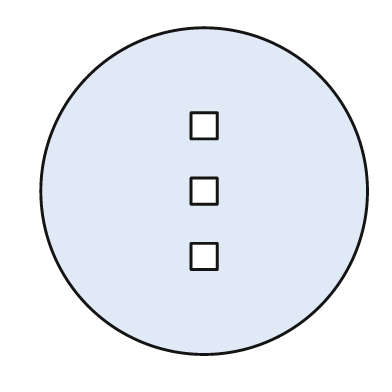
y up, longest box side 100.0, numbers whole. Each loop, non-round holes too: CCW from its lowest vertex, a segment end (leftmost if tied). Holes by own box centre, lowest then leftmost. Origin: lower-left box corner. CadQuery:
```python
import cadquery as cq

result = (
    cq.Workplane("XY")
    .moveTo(50.0, 50.0)
    .circle(50.0)
    .moveTo(46.0, 26.0)
    .lineTo(54.0, 26.0)
    .lineTo(54.0, 34.0)
    .lineTo(46.0, 34.0)
    .close()
    .moveTo(46.0, 46.0)
    .lineTo(54.0, 46.0)
    .lineTo(54.0, 54.0)
    .lineTo(46.0, 54.0)
    .close()
    .moveTo(46.0, 66.0)
    .lineTo(54.0, 66.0)
    .lineTo(54.0, 74.0)
    .lineTo(46.0, 74.0)
    .close()
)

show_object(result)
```